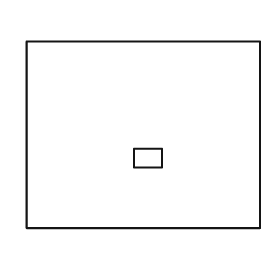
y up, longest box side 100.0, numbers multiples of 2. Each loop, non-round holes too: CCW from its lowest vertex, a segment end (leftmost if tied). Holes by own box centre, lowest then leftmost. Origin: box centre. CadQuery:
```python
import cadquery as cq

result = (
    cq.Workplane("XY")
    .moveTo(-50.0, -40.0)
    .lineTo(50.0, -40.0)
    .lineTo(50.0, 40.0)
    .lineTo(-50.0, 40.0)
    .close()
    .moveTo(-4.0, -14.0)
    .lineTo(8.0, -14.0)
    .lineTo(8.0, -6.0)
    .lineTo(-4.0, -6.0)
    .close()
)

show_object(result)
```